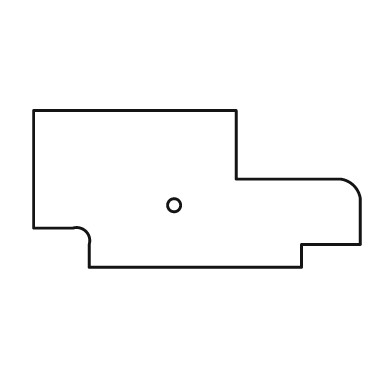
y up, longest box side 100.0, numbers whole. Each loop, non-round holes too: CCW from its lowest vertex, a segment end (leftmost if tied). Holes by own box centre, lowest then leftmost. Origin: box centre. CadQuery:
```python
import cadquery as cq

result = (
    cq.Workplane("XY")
    .moveTo(-33.0, -24.0)
    .lineTo(32.0, -24.0)
    .lineTo(32.0, -17.0)
    .lineTo(50.0, -17.0)
    .lineTo(50.0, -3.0)
    .threePointArc((48.0, 1.0), (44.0, 3.0))
    .lineTo(12.0, 3.0)
    .lineTo(12.0, 24.0)
    .lineTo(-50.0, 24.0)
    .lineTo(-50.0, -12.0)
    .lineTo(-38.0, -12.0)
    .threePointArc((-34.0, -13.0), (-33.0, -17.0))
    .close()
    .moveTo(-7.0, -5.0)
    .circle(2.0)
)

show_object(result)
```